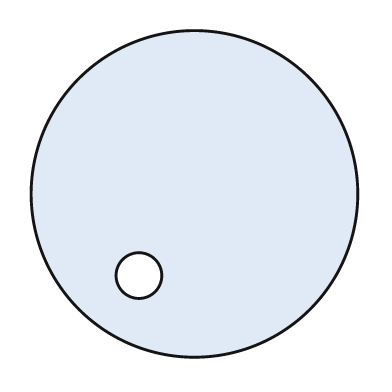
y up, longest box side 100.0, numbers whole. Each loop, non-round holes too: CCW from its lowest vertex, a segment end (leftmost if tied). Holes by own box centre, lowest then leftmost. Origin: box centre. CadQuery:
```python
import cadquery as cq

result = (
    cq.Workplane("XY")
    .moveTo(0.0, 0.0)
    .circle(50.0)
    .moveTo(-17.0, -25.0)
    .circle(7.0)
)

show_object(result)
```